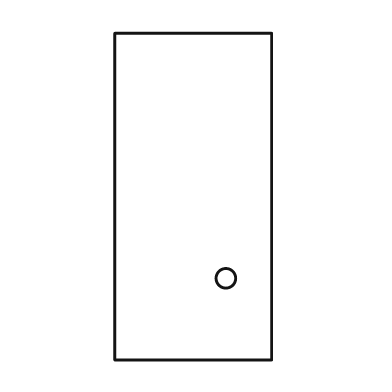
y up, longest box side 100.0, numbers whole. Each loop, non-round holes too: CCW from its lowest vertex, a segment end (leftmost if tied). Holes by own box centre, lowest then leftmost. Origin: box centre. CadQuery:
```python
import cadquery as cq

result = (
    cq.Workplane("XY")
    .moveTo(-24.0, -50.0)
    .lineTo(24.0, -50.0)
    .lineTo(24.0, 50.0)
    .lineTo(-24.0, 50.0)
    .close()
    .moveTo(10.0, -25.0)
    .circle(3.0)
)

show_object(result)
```